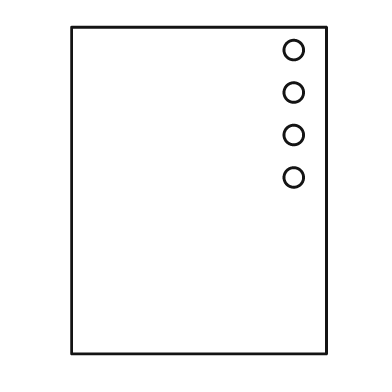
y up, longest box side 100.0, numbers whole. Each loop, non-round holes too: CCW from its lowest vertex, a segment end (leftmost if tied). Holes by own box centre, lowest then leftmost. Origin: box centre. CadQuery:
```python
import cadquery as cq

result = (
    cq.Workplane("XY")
    .moveTo(-39.0, -50.0)
    .lineTo(39.0, -50.0)
    .lineTo(39.0, 50.0)
    .lineTo(-39.0, 50.0)
    .close()
    .moveTo(29.0, 4.0)
    .circle(3.0)
    .moveTo(29.0, 17.0)
    .circle(3.0)
    .moveTo(29.0, 30.0)
    .circle(3.0)
    .moveTo(29.0, 43.0)
    .circle(3.0)
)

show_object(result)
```